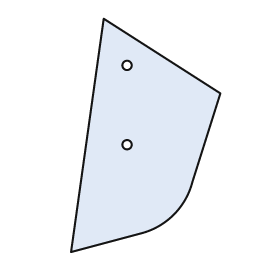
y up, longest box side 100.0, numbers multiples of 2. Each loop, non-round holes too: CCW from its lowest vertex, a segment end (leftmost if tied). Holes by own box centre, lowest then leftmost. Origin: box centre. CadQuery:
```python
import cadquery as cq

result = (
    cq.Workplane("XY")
    .moveTo(-32.0, -50.0)
    .lineTo(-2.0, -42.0)
    .threePointArc((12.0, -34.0), (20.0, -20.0))
    .lineTo(32.0, 18.0)
    .lineTo(-18.0, 50.0)
    .close()
    .moveTo(-8.0, -4.0)
    .circle(2.0)
    .moveTo(-8.0, 30.0)
    .circle(2.0)
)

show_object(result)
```